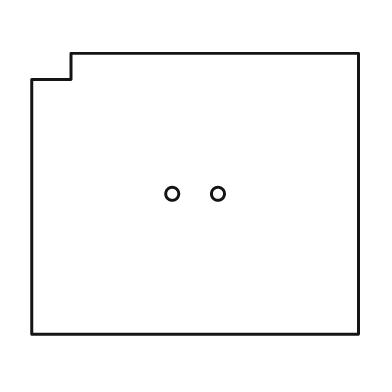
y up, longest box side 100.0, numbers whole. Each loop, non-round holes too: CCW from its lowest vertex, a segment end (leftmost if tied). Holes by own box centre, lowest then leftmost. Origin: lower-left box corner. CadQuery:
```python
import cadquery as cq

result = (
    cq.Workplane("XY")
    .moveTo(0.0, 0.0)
    .lineTo(100.0, 0.0)
    .lineTo(100.0, 86.0)
    .lineTo(12.0, 86.0)
    .lineTo(12.0, 78.0)
    .lineTo(0.0, 78.0)
    .close()
    .moveTo(43.0, 43.0)
    .circle(2.0)
    .moveTo(57.0, 43.0)
    .circle(2.0)
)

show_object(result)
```